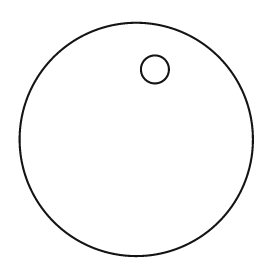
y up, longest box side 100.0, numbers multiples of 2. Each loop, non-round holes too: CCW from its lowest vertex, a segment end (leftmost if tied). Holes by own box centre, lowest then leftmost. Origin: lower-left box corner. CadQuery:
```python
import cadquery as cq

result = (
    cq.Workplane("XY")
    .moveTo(50.0, 50.0)
    .circle(50.0)
    .moveTo(58.0, 80.0)
    .circle(6.0)
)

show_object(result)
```